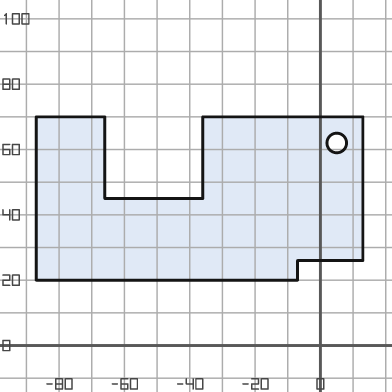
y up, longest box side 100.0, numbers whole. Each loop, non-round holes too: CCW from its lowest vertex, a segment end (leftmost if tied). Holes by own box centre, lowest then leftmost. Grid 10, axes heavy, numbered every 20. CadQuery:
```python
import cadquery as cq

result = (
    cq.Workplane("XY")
    .moveTo(-87.0, 20.0)
    .lineTo(-7.0, 20.0)
    .lineTo(-7.0, 26.0)
    .lineTo(13.0, 26.0)
    .lineTo(13.0, 70.0)
    .lineTo(-36.0, 70.0)
    .lineTo(-36.0, 45.0)
    .lineTo(-66.0, 45.0)
    .lineTo(-66.0, 70.0)
    .lineTo(-87.0, 70.0)
    .close()
    .moveTo(5.0, 62.0)
    .circle(3.0)
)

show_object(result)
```